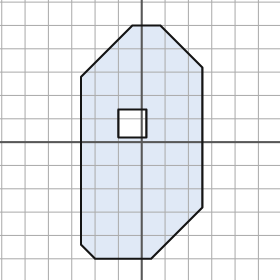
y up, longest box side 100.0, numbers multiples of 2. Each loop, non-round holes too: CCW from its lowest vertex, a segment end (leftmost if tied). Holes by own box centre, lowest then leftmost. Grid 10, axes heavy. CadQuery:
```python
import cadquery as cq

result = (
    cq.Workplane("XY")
    .moveTo(-20.0, -50.0)
    .lineTo(4.0, -50.0)
    .lineTo(26.0, -28.0)
    .lineTo(26.0, 32.0)
    .lineTo(8.0, 50.0)
    .lineTo(-4.0, 50.0)
    .lineTo(-26.0, 28.0)
    .lineTo(-26.0, -44.0)
    .close()
    .moveTo(-10.0, 2.0)
    .lineTo(2.0, 2.0)
    .lineTo(2.0, 14.0)
    .lineTo(-10.0, 14.0)
    .close()
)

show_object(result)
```